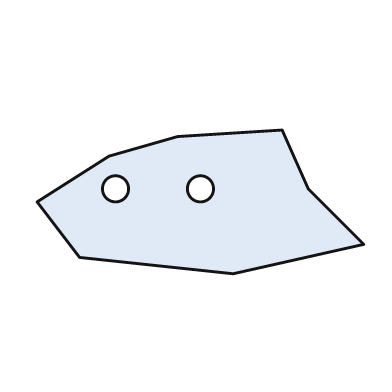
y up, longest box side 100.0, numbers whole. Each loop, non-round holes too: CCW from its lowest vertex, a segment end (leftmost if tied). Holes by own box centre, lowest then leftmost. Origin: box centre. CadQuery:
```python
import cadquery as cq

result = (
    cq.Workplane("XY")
    .moveTo(10.0, -22.0)
    .lineTo(50.0, -13.0)
    .lineTo(33.0, 4.0)
    .lineTo(25.0, 22.0)
    .lineTo(-7.0, 20.0)
    .lineTo(-28.0, 14.0)
    .lineTo(-50.0, 0.0)
    .lineTo(-37.0, -17.0)
    .close()
    .moveTo(-26.0, 4.0)
    .circle(4.0)
    .moveTo(0.0, 4.0)
    .circle(4.0)
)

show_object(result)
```